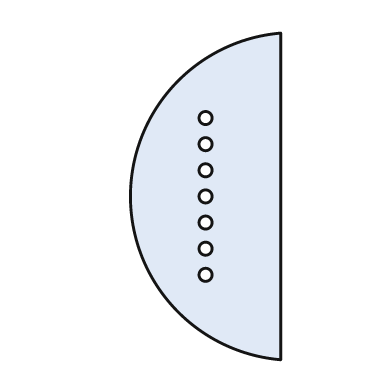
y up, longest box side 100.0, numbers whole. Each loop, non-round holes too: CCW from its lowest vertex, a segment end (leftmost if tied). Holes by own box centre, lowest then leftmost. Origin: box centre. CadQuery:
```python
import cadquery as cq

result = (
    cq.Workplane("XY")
    .moveTo(23.0, -50.0)
    .lineTo(23.0, 50.0)
    .threePointArc((-23.0, 0.0), (23.0, -50.0))
    .close()
    .moveTo(0.0, -24.0)
    .circle(2.0)
    .moveTo(0.0, -16.0)
    .circle(2.0)
    .moveTo(0.0, -8.0)
    .circle(2.0)
    .moveTo(0.0, 0.0)
    .circle(2.0)
    .moveTo(0.0, 8.0)
    .circle(2.0)
    .moveTo(0.0, 16.0)
    .circle(2.0)
    .moveTo(0.0, 24.0)
    .circle(2.0)
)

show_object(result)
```